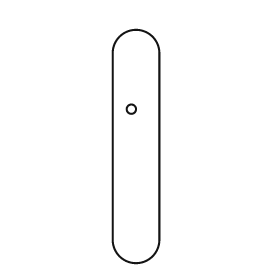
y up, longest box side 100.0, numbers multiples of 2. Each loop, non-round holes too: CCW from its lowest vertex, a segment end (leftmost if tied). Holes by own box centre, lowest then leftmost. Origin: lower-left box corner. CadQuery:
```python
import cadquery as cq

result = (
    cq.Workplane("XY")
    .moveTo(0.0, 10.0)
    .threePointArc((10.0, 0.0), (20.0, 10.0))
    .lineTo(20.0, 90.0)
    .threePointArc((10.0, 100.0), (0.0, 90.0))
    .close()
    .moveTo(8.0, 66.0)
    .circle(2.0)
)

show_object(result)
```